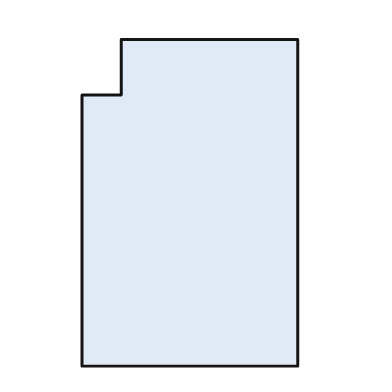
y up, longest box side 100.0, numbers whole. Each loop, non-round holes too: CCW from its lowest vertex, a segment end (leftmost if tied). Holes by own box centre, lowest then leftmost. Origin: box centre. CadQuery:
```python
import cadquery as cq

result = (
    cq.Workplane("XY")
    .moveTo(-33.0, -50.0)
    .lineTo(33.0, -50.0)
    .lineTo(33.0, 50.0)
    .lineTo(-21.0, 50.0)
    .lineTo(-21.0, 33.0)
    .lineTo(-33.0, 33.0)
    .close()
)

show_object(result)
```